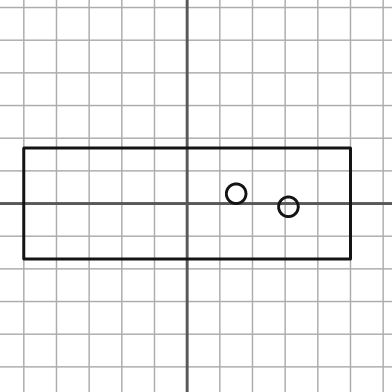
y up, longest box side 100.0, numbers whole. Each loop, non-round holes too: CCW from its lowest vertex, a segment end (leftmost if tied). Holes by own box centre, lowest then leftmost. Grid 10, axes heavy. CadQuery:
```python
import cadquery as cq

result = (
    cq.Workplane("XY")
    .moveTo(-50.0, -17.0)
    .lineTo(50.0, -17.0)
    .lineTo(50.0, 17.0)
    .lineTo(-50.0, 17.0)
    .close()
    .moveTo(31.0, -1.0)
    .circle(3.0)
    .moveTo(15.0, 3.0)
    .circle(3.0)
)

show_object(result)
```